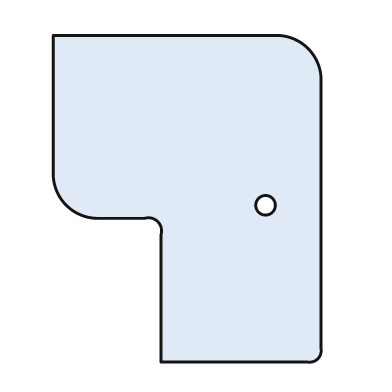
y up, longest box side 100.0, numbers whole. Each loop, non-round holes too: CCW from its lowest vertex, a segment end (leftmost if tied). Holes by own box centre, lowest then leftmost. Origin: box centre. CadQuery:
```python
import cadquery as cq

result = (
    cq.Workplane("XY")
    .moveTo(-8.0, -50.0)
    .lineTo(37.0, -50.0)
    .threePointArc((40.0, -49.0), (41.0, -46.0))
    .lineTo(41.0, 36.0)
    .threePointArc((37.0, 46.0), (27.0, 50.0))
    .lineTo(-41.0, 50.0)
    .lineTo(-41.0, 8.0)
    .threePointArc((-37.0, -2.0), (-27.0, -6.0))
    .lineTo(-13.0, -6.0)
    .threePointArc((-9.0, -7.0), (-8.0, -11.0))
    .close()
    .moveTo(24.0, -2.0)
    .circle(3.0)
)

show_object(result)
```